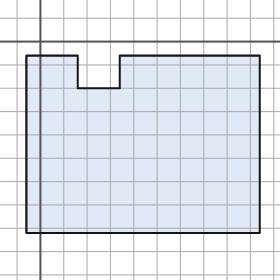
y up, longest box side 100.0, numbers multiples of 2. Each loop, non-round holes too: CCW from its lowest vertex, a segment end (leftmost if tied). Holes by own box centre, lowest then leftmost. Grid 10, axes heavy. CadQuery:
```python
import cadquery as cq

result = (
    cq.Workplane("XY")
    .moveTo(-6.0, -82.0)
    .lineTo(94.0, -82.0)
    .lineTo(94.0, -6.0)
    .lineTo(34.0, -6.0)
    .lineTo(34.0, -20.0)
    .lineTo(16.0, -20.0)
    .lineTo(16.0, -6.0)
    .lineTo(-6.0, -6.0)
    .close()
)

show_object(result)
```